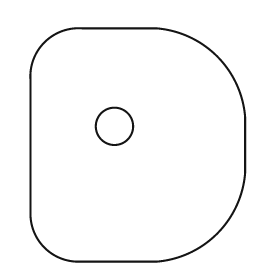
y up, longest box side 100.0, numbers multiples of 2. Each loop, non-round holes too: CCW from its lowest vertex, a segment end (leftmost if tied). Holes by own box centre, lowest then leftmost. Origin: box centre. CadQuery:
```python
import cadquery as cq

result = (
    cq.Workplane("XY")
    .moveTo(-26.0, -50.0)
    .lineTo(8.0, -50.0)
    .threePointArc((34.0, -38.0), (46.0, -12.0))
    .lineTo(46.0, 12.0)
    .threePointArc((34.0, 38.0), (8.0, 50.0))
    .lineTo(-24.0, 50.0)
    .threePointArc((-40.0, 44.0), (-46.0, 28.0))
    .lineTo(-46.0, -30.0)
    .threePointArc((-40.0, -44.0), (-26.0, -50.0))
    .close()
    .moveTo(-10.0, 8.0)
    .circle(8.0)
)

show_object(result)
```